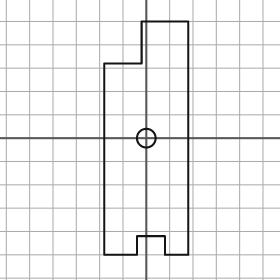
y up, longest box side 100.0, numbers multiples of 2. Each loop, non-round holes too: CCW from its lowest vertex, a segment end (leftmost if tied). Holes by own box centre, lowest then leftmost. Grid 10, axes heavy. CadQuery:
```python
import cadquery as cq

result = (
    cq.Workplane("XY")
    .moveTo(-18.0, -50.0)
    .lineTo(-4.0, -50.0)
    .lineTo(-4.0, -42.0)
    .lineTo(8.0, -42.0)
    .lineTo(8.0, -50.0)
    .lineTo(18.0, -50.0)
    .lineTo(18.0, 50.0)
    .lineTo(-2.0, 50.0)
    .lineTo(-2.0, 32.0)
    .lineTo(-18.0, 32.0)
    .close()
    .moveTo(0.0, 0.0)
    .circle(4.0)
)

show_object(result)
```